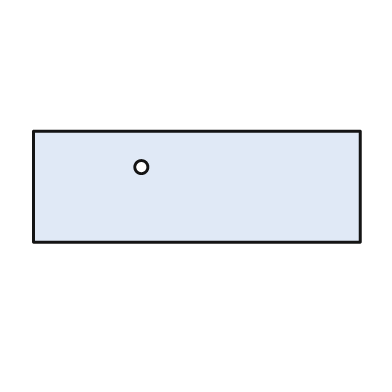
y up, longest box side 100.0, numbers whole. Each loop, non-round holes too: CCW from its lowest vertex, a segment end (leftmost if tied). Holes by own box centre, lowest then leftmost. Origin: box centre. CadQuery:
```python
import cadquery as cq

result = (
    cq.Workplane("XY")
    .moveTo(-50.0, -17.0)
    .lineTo(50.0, -17.0)
    .lineTo(50.0, 17.0)
    .lineTo(-50.0, 17.0)
    .close()
    .moveTo(-17.0, 6.0)
    .circle(2.0)
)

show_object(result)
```